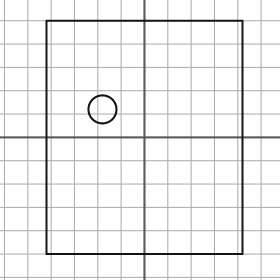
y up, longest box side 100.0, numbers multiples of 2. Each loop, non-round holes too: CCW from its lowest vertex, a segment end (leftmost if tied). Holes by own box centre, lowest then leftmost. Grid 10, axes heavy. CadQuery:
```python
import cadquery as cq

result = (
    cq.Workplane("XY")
    .moveTo(-42.0, -50.0)
    .lineTo(42.0, -50.0)
    .lineTo(42.0, 50.0)
    .lineTo(-42.0, 50.0)
    .close()
    .moveTo(-18.0, 12.0)
    .circle(6.0)
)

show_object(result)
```